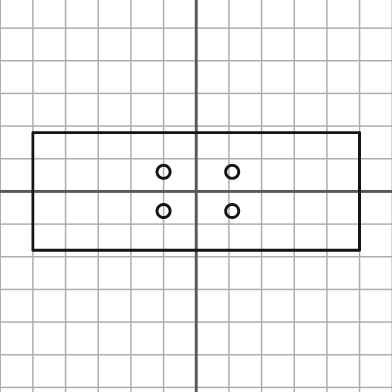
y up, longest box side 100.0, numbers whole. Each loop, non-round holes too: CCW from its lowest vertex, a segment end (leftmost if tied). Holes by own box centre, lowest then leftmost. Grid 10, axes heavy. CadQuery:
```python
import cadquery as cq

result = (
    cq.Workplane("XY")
    .moveTo(-50.0, -18.0)
    .lineTo(50.0, -18.0)
    .lineTo(50.0, 18.0)
    .lineTo(-50.0, 18.0)
    .close()
    .moveTo(-10.0, -6.0)
    .circle(2.0)
    .moveTo(11.0, -6.0)
    .circle(2.0)
    .moveTo(-10.0, 6.0)
    .circle(2.0)
    .moveTo(11.0, 6.0)
    .circle(2.0)
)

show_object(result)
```